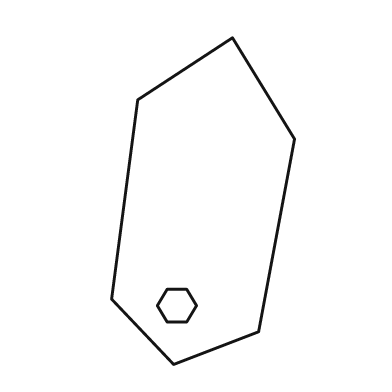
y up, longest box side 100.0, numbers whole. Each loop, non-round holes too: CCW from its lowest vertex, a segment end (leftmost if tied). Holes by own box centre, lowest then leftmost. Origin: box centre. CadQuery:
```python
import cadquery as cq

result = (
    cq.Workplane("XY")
    .moveTo(-9.0, -50.0)
    .lineTo(17.0, -40.0)
    .lineTo(28.0, 19.0)
    .lineTo(9.0, 50.0)
    .lineTo(-20.0, 31.0)
    .lineTo(-28.0, -30.0)
    .close()
    .moveTo(-11.0, -37.0)
    .lineTo(-5.0, -37.0)
    .lineTo(-2.0, -32.0)
    .lineTo(-5.0, -27.0)
    .lineTo(-11.0, -27.0)
    .lineTo(-14.0, -32.0)
    .close()
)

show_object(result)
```